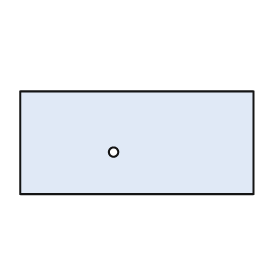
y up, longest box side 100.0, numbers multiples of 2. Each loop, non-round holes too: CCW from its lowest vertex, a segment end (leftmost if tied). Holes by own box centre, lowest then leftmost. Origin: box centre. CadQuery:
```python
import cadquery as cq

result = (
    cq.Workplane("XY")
    .moveTo(-50.0, -22.0)
    .lineTo(50.0, -22.0)
    .lineTo(50.0, 22.0)
    .lineTo(-50.0, 22.0)
    .close()
    .moveTo(-10.0, -4.0)
    .circle(2.0)
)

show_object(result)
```